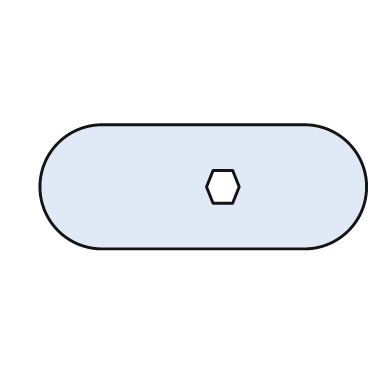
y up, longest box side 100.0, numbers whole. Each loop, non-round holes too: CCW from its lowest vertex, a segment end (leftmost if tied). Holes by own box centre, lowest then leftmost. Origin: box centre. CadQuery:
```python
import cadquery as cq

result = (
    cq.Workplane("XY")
    .moveTo(-31.0, -19.0)
    .lineTo(31.0, -19.0)
    .threePointArc((50.0, 0.0), (31.0, 19.0))
    .lineTo(-31.0, 19.0)
    .threePointArc((-50.0, 0.0), (-31.0, -19.0))
    .close()
    .moveTo(3.0, -5.0)
    .lineTo(9.0, -5.0)
    .lineTo(11.0, 0.0)
    .lineTo(9.0, 5.0)
    .lineTo(3.0, 5.0)
    .lineTo(1.0, 0.0)
    .close()
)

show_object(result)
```